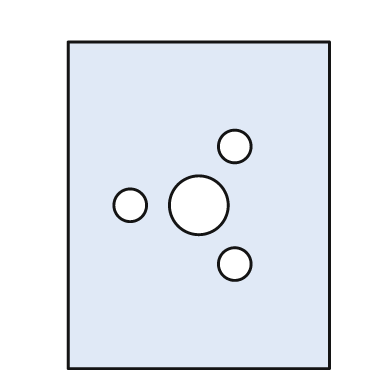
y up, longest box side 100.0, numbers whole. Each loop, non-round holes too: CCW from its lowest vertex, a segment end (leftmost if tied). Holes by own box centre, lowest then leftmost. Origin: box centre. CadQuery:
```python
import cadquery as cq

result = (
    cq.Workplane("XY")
    .moveTo(-40.0, -50.0)
    .lineTo(40.0, -50.0)
    .lineTo(40.0, 50.0)
    .lineTo(-40.0, 50.0)
    .close()
    .moveTo(11.0, -18.0)
    .circle(5.0)
    .moveTo(-21.0, 0.0)
    .circle(5.0)
    .moveTo(0.0, 0.0)
    .circle(9.0)
    .moveTo(11.0, 18.0)
    .circle(5.0)
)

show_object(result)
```